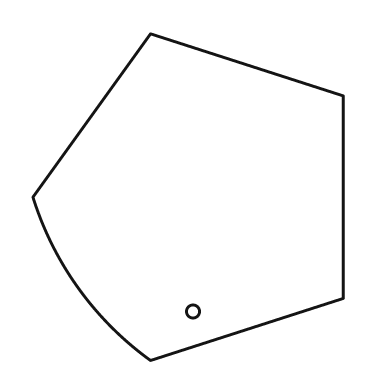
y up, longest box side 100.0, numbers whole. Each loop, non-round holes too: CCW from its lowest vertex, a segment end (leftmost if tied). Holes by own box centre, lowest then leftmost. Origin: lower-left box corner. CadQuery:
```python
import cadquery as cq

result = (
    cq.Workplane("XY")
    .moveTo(36.0, 0.0)
    .lineTo(95.0, 19.0)
    .lineTo(95.0, 81.0)
    .lineTo(36.0, 100.0)
    .lineTo(0.0, 50.0)
    .threePointArc((14.0, 22.0), (36.0, 0.0))
    .close()
    .moveTo(49.0, 15.0)
    .circle(2.0)
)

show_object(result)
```